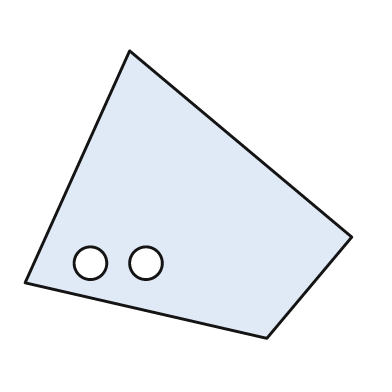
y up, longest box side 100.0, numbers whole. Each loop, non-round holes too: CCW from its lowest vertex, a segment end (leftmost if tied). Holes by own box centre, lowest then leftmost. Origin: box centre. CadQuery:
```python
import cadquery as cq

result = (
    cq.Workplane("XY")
    .moveTo(24.0, -44.0)
    .lineTo(50.0, -13.0)
    .lineTo(-18.0, 44.0)
    .lineTo(-50.0, -27.0)
    .close()
    .moveTo(-30.0, -21.0)
    .circle(5.0)
    .moveTo(-13.0, -21.0)
    .circle(5.0)
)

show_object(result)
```